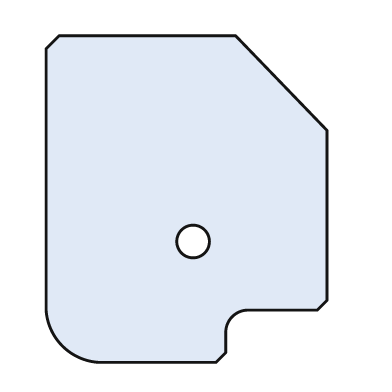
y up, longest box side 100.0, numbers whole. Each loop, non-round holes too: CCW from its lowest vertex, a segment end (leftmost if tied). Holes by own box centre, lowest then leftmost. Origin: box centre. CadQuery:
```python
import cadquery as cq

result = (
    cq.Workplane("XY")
    .moveTo(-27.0, -50.0)
    .lineTo(9.0, -50.0)
    .lineTo(12.0, -47.0)
    .lineTo(12.0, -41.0)
    .threePointArc((14.0, -36.0), (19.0, -34.0))
    .lineTo(40.0, -34.0)
    .lineTo(43.0, -31.0)
    .lineTo(43.0, 21.0)
    .lineTo(15.0, 50.0)
    .lineTo(-39.0, 50.0)
    .lineTo(-43.0, 46.0)
    .lineTo(-43.0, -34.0)
    .threePointArc((-38.0, -45.0), (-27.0, -50.0))
    .close()
    .moveTo(2.0, -13.0)
    .circle(5.0)
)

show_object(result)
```